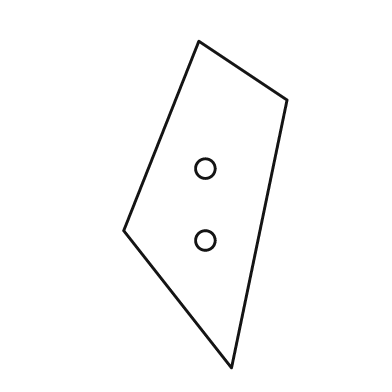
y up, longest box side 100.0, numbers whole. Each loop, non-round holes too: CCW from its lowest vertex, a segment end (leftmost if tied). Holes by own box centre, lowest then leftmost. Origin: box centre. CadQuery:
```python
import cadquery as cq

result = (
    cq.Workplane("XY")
    .moveTo(8.0, -50.0)
    .lineTo(25.0, 32.0)
    .lineTo(-2.0, 50.0)
    .lineTo(-25.0, -8.0)
    .close()
    .moveTo(0.0, -11.0)
    .circle(3.0)
    .moveTo(0.0, 11.0)
    .circle(3.0)
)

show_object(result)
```